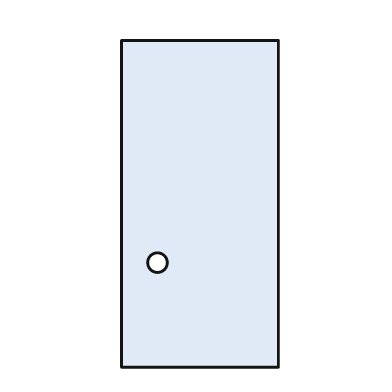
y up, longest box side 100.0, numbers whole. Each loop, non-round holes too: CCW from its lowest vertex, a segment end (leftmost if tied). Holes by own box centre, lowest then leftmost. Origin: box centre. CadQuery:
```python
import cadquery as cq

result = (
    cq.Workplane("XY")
    .moveTo(-24.0, -50.0)
    .lineTo(24.0, -50.0)
    .lineTo(24.0, 50.0)
    .lineTo(-24.0, 50.0)
    .close()
    .moveTo(-13.0, -18.0)
    .circle(3.0)
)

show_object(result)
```